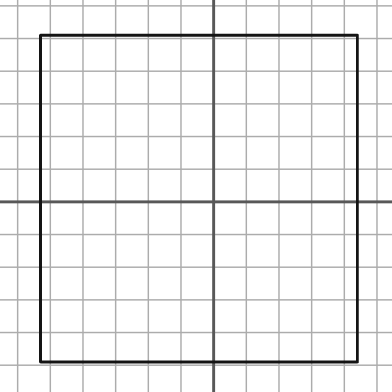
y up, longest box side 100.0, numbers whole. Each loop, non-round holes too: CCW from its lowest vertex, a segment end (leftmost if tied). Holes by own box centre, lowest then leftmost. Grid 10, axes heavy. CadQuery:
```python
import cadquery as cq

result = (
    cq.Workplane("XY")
    .moveTo(-53.0, -49.0)
    .lineTo(44.0, -49.0)
    .lineTo(44.0, 51.0)
    .lineTo(-53.0, 51.0)
    .close()
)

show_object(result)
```